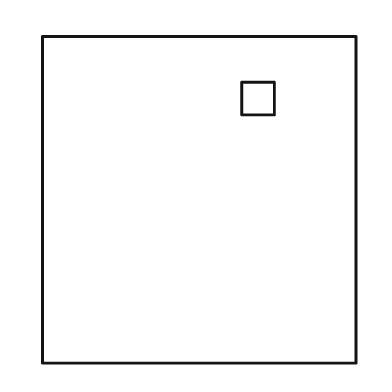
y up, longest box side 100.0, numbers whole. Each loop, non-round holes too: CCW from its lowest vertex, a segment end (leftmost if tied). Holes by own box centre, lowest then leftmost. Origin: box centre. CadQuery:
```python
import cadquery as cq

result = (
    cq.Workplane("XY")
    .moveTo(-48.0, -50.0)
    .lineTo(48.0, -50.0)
    .lineTo(48.0, 50.0)
    .lineTo(-48.0, 50.0)
    .close()
    .moveTo(13.0, 26.0)
    .lineTo(23.0, 26.0)
    .lineTo(23.0, 36.0)
    .lineTo(13.0, 36.0)
    .close()
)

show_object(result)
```